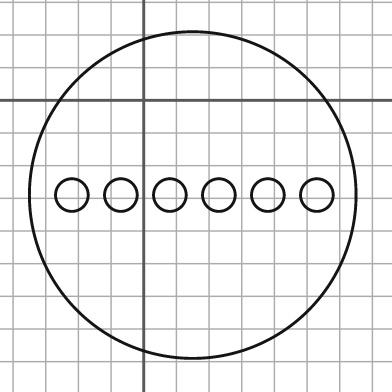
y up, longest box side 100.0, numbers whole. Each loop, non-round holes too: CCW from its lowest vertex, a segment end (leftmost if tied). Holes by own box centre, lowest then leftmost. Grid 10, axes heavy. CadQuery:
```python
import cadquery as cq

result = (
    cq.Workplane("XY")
    .moveTo(15.0, -29.0)
    .circle(50.0)
    .moveTo(-22.0, -29.0)
    .circle(5.0)
    .moveTo(-7.0, -29.0)
    .circle(5.0)
    .moveTo(8.0, -29.0)
    .circle(5.0)
    .moveTo(23.0, -29.0)
    .circle(5.0)
    .moveTo(38.0, -29.0)
    .circle(5.0)
    .moveTo(53.0, -29.0)
    .circle(5.0)
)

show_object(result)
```